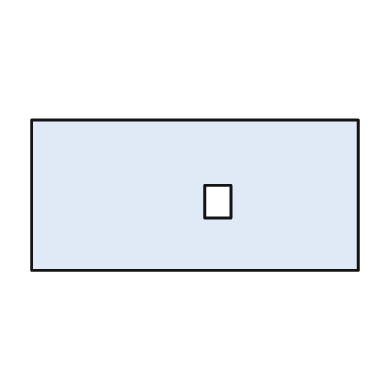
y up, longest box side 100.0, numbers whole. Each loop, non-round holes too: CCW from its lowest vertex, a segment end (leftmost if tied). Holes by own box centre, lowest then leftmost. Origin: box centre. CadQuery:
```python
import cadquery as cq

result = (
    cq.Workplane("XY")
    .moveTo(-50.0, -23.0)
    .lineTo(50.0, -23.0)
    .lineTo(50.0, 23.0)
    .lineTo(-50.0, 23.0)
    .close()
    .moveTo(3.0, -7.0)
    .lineTo(11.0, -7.0)
    .lineTo(11.0, 3.0)
    .lineTo(3.0, 3.0)
    .close()
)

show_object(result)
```